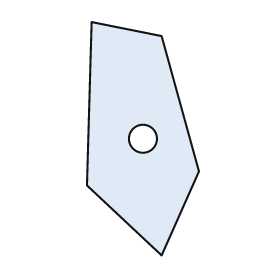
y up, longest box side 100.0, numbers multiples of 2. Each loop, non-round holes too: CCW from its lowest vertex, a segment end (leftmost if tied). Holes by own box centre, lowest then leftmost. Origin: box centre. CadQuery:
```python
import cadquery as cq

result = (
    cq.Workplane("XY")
    .moveTo(8.0, -50.0)
    .lineTo(24.0, -14.0)
    .lineTo(8.0, 44.0)
    .lineTo(-22.0, 50.0)
    .lineTo(-24.0, -20.0)
    .close()
    .moveTo(0.0, 0.0)
    .circle(6.0)
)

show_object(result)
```